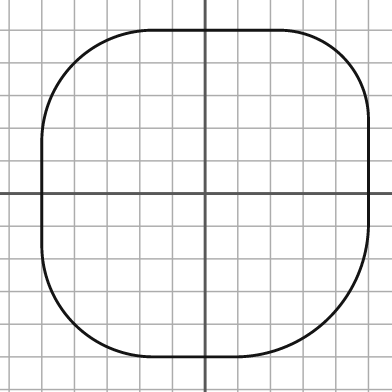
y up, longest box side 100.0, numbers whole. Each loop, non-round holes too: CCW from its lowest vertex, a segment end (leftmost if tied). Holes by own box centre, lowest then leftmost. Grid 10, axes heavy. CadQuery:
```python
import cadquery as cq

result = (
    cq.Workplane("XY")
    .moveTo(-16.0, -50.0)
    .lineTo(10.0, -50.0)
    .threePointArc((38.0, -38.0), (50.0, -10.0))
    .lineTo(50.0, 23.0)
    .threePointArc((42.0, 42.0), (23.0, 50.0))
    .lineTo(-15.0, 50.0)
    .threePointArc((-40.0, 40.0), (-50.0, 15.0))
    .lineTo(-50.0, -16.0)
    .threePointArc((-40.0, -40.0), (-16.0, -50.0))
    .close()
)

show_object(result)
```